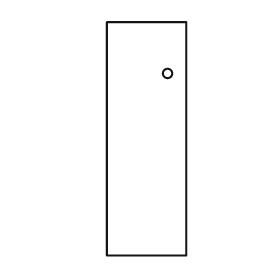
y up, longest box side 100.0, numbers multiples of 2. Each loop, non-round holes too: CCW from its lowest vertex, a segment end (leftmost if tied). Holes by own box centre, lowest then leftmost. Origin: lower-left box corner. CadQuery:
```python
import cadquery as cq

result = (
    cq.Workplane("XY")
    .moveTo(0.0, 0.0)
    .lineTo(34.0, 0.0)
    .lineTo(34.0, 100.0)
    .lineTo(0.0, 100.0)
    .close()
    .moveTo(26.0, 78.0)
    .circle(2.0)
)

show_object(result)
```